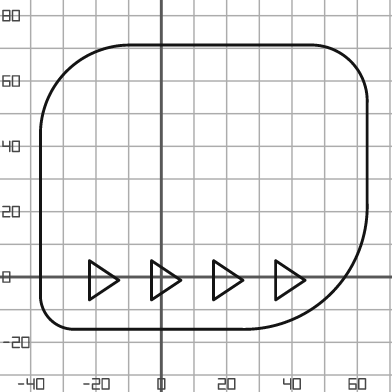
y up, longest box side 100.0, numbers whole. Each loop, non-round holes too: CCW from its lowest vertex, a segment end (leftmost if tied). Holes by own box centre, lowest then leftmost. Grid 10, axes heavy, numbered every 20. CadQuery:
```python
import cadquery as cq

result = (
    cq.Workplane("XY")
    .moveTo(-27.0, -16.0)
    .lineTo(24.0, -16.0)
    .threePointArc((52.0, -5.0), (63.0, 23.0))
    .lineTo(63.0, 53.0)
    .threePointArc((58.0, 66.0), (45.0, 71.0))
    .lineTo(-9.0, 71.0)
    .threePointArc((-29.0, 63.0), (-37.0, 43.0))
    .lineTo(-37.0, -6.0)
    .threePointArc((-34.0, -13.0), (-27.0, -16.0))
    .close()
    .moveTo(-22.0, -7.0)
    .lineTo(-13.0, -1.0)
    .lineTo(-22.0, 5.0)
    .close()
    .moveTo(-3.0, -7.0)
    .lineTo(6.0, -1.0)
    .lineTo(-3.0, 5.0)
    .close()
    .moveTo(16.0, -7.0)
    .lineTo(25.0, -1.0)
    .lineTo(16.0, 5.0)
    .close()
    .moveTo(35.0, -7.0)
    .lineTo(44.0, -1.0)
    .lineTo(35.0, 5.0)
    .close()
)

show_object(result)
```